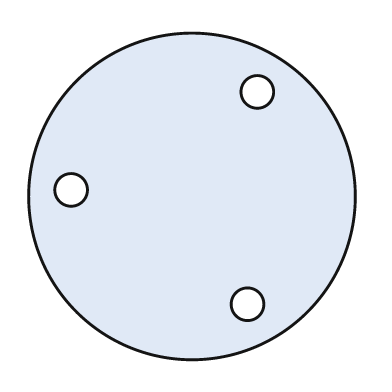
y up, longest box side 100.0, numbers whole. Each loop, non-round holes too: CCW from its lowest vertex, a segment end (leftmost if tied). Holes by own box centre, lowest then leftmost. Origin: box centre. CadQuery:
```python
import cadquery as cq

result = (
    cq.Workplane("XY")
    .moveTo(0.0, 0.0)
    .circle(50.0)
    .moveTo(17.0, -33.0)
    .circle(5.0)
    .moveTo(-37.0, 2.0)
    .circle(5.0)
    .moveTo(20.0, 32.0)
    .circle(5.0)
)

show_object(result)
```